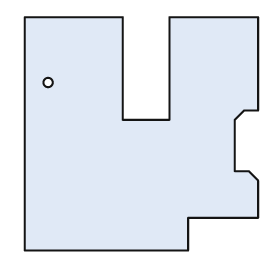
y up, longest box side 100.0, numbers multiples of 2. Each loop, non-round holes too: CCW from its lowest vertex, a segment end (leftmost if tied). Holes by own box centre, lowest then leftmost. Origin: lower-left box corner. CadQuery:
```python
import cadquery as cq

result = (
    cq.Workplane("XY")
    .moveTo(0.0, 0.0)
    .lineTo(70.0, 0.0)
    .lineTo(70.0, 14.0)
    .lineTo(100.0, 14.0)
    .lineTo(100.0, 30.0)
    .lineTo(96.0, 34.0)
    .lineTo(90.0, 34.0)
    .lineTo(90.0, 56.0)
    .lineTo(94.0, 60.0)
    .lineTo(100.0, 60.0)
    .lineTo(100.0, 100.0)
    .lineTo(62.0, 100.0)
    .lineTo(62.0, 56.0)
    .lineTo(42.0, 56.0)
    .lineTo(42.0, 100.0)
    .lineTo(0.0, 100.0)
    .close()
    .moveTo(10.0, 72.0)
    .circle(2.0)
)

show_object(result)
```